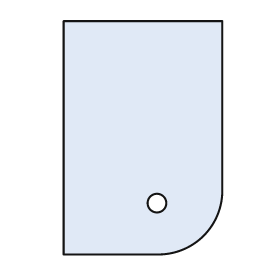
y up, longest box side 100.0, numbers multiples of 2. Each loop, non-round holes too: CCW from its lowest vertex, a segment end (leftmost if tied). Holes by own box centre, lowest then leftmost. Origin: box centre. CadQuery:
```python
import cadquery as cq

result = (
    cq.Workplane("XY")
    .moveTo(-34.0, -50.0)
    .lineTo(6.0, -50.0)
    .threePointArc((26.0, -42.0), (34.0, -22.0))
    .lineTo(34.0, 50.0)
    .lineTo(-34.0, 50.0)
    .close()
    .moveTo(6.0, -28.0)
    .circle(4.0)
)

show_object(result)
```